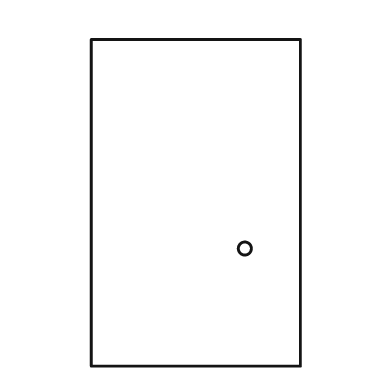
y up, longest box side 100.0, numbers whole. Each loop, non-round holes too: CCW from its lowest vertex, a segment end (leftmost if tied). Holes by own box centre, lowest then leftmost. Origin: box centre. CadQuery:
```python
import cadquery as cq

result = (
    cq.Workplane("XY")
    .moveTo(-32.0, -50.0)
    .lineTo(32.0, -50.0)
    .lineTo(32.0, 50.0)
    .lineTo(-32.0, 50.0)
    .close()
    .moveTo(15.0, -14.0)
    .circle(2.0)
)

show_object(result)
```